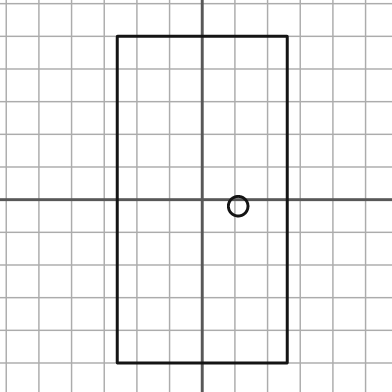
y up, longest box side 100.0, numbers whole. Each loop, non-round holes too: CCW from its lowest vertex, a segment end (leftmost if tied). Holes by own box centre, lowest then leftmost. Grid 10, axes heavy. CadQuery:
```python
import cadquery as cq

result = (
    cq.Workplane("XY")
    .moveTo(-26.0, -50.0)
    .lineTo(26.0, -50.0)
    .lineTo(26.0, 50.0)
    .lineTo(-26.0, 50.0)
    .close()
    .moveTo(11.0, -2.0)
    .circle(3.0)
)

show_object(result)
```